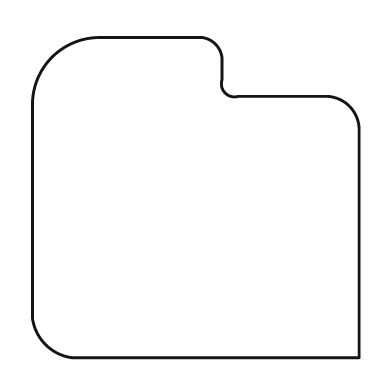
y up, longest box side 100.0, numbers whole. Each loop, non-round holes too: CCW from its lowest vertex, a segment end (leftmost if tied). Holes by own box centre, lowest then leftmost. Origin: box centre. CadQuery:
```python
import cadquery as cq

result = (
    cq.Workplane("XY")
    .moveTo(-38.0, -49.0)
    .lineTo(50.0, -49.0)
    .lineTo(50.0, 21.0)
    .threePointArc((47.0, 28.0), (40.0, 31.0))
    .lineTo(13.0, 31.0)
    .threePointArc((9.0, 32.0), (8.0, 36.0))
    .lineTo(8.0, 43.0)
    .threePointArc((6.0, 47.0), (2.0, 49.0))
    .lineTo(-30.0, 49.0)
    .threePointArc((-44.0, 43.0), (-50.0, 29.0))
    .lineTo(-50.0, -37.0)
    .threePointArc((-46.0, -45.0), (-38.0, -49.0))
    .close()
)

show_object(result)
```